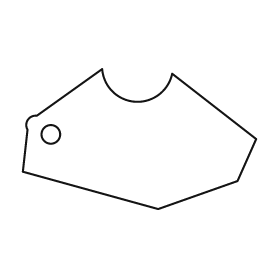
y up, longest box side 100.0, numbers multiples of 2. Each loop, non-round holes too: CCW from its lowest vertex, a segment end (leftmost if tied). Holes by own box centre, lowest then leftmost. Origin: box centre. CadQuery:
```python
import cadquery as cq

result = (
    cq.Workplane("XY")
    .moveTo(8.0, -30.0)
    .lineTo(42.0, -18.0)
    .lineTo(50.0, 0.0)
    .lineTo(14.0, 28.0)
    .threePointArc((-2.0, 16.0), (-16.0, 30.0))
    .lineTo(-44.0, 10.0)
    .threePointArc((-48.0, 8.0), (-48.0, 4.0))
    .lineTo(-50.0, -14.0)
    .close()
    .moveTo(-38.0, 2.0)
    .circle(4.0)
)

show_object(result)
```